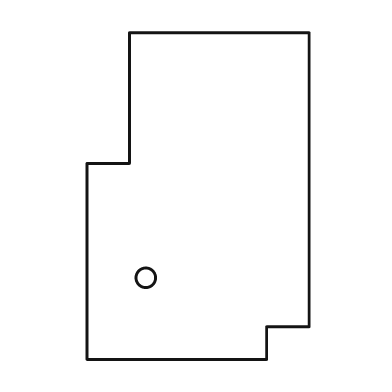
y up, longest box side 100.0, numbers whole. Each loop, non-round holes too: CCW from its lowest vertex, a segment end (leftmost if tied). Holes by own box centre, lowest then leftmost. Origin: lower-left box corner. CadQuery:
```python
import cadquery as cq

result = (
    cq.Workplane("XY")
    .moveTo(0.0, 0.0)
    .lineTo(55.0, 0.0)
    .lineTo(55.0, 10.0)
    .lineTo(68.0, 10.0)
    .lineTo(68.0, 100.0)
    .lineTo(13.0, 100.0)
    .lineTo(13.0, 60.0)
    .lineTo(0.0, 60.0)
    .close()
    .moveTo(18.0, 25.0)
    .circle(3.0)
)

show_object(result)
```